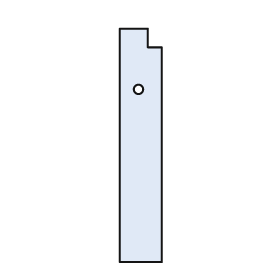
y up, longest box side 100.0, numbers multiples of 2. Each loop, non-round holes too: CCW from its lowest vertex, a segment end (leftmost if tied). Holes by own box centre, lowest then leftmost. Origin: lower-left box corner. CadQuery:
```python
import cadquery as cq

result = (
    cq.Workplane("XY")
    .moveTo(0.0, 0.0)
    .lineTo(18.0, 0.0)
    .lineTo(18.0, 92.0)
    .lineTo(12.0, 92.0)
    .lineTo(12.0, 100.0)
    .lineTo(0.0, 100.0)
    .close()
    .moveTo(8.0, 74.0)
    .circle(2.0)
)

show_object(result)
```